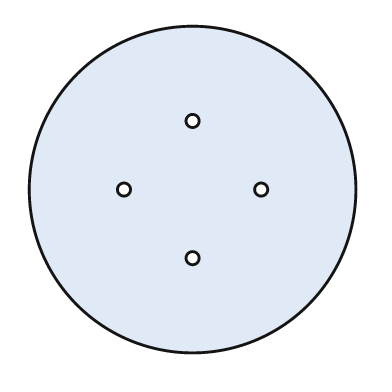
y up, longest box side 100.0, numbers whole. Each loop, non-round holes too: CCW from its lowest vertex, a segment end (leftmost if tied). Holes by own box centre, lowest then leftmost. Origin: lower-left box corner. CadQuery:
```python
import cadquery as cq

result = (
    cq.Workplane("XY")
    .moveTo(50.0, 50.0)
    .circle(50.0)
    .moveTo(50.0, 29.0)
    .circle(2.0)
    .moveTo(29.0, 50.0)
    .circle(2.0)
    .moveTo(71.0, 50.0)
    .circle(2.0)
    .moveTo(50.0, 71.0)
    .circle(2.0)
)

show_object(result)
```